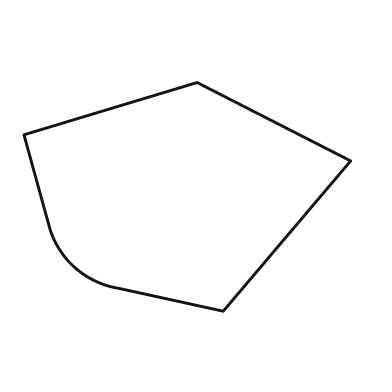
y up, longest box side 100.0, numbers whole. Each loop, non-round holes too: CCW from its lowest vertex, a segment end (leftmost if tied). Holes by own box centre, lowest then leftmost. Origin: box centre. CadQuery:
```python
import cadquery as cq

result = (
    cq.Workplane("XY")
    .moveTo(11.0, -35.0)
    .lineTo(50.0, 11.0)
    .lineTo(3.0, 35.0)
    .lineTo(-50.0, 19.0)
    .lineTo(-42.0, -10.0)
    .threePointArc((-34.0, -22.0), (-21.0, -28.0))
    .close()
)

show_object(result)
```